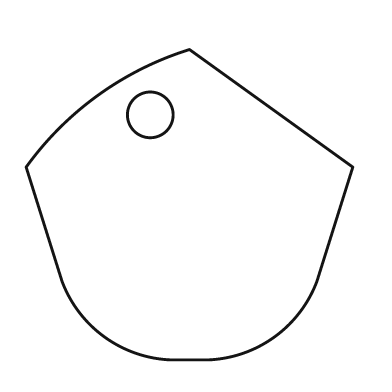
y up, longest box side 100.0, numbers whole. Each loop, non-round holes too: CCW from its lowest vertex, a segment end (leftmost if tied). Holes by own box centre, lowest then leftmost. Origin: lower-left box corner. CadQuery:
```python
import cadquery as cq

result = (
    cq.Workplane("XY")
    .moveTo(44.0, 0.0)
    .lineTo(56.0, 0.0)
    .threePointArc((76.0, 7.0), (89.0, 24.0))
    .lineTo(100.0, 59.0)
    .lineTo(50.0, 95.0)
    .threePointArc((22.0, 81.0), (0.0, 59.0))
    .lineTo(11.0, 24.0)
    .threePointArc((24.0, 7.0), (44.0, 0.0))
    .close()
    .moveTo(38.0, 75.0)
    .circle(7.0)
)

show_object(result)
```